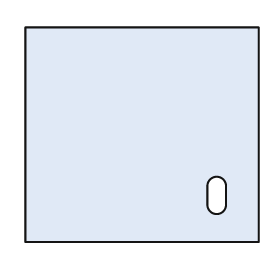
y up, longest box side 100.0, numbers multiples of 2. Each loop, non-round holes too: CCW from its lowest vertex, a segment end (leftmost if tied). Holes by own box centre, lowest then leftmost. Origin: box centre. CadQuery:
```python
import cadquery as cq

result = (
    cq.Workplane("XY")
    .moveTo(-50.0, -46.0)
    .lineTo(50.0, -46.0)
    .lineTo(50.0, 46.0)
    .lineTo(-50.0, 46.0)
    .close()
    .moveTo(28.0, -30.0)
    .threePointArc((32.0, -34.0), (36.0, -30.0))
    .lineTo(36.0, -22.0)
    .threePointArc((32.0, -18.0), (28.0, -22.0))
    .close()
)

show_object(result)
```